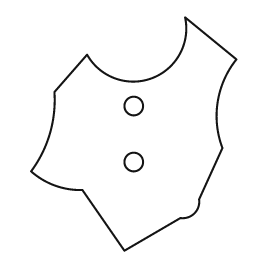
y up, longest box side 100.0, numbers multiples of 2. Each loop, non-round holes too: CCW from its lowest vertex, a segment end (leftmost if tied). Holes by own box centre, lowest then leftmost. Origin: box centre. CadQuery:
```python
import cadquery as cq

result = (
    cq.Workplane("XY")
    .moveTo(-4.0, -50.0)
    .lineTo(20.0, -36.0)
    .threePointArc((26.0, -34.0), (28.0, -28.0))
    .lineTo(38.0, -6.0)
    .threePointArc((36.0, 14.0), (44.0, 32.0))
    .lineTo(22.0, 50.0)
    .threePointArc((8.0, 24.0), (-20.0, 34.0))
    .lineTo(-34.0, 18.0)
    .threePointArc((-36.0, 0.0), (-44.0, -16.0))
    .threePointArc((-34.0, -22.0), (-22.0, -24.0))
    .close()
    .moveTo(0.0, -12.0)
    .circle(4.0)
    .moveTo(0.0, 12.0)
    .circle(4.0)
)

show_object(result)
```